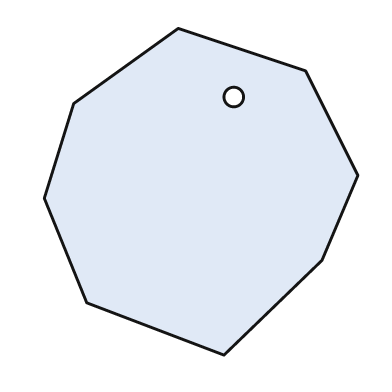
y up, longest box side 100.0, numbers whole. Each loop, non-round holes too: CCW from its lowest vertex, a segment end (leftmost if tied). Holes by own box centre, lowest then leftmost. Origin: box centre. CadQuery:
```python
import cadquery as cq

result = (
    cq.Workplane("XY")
    .moveTo(7.0, -50.0)
    .lineTo(37.0, -21.0)
    .lineTo(48.0, 5.0)
    .lineTo(32.0, 37.0)
    .lineTo(-7.0, 50.0)
    .lineTo(-39.0, 27.0)
    .lineTo(-48.0, -2.0)
    .lineTo(-35.0, -34.0)
    .close()
    .moveTo(10.0, 29.0)
    .circle(3.0)
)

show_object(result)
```